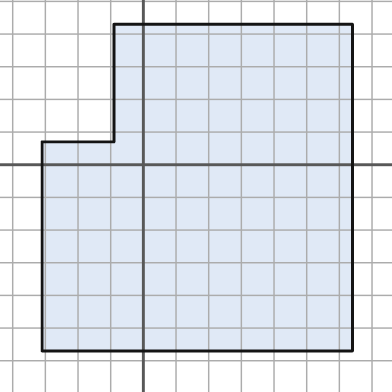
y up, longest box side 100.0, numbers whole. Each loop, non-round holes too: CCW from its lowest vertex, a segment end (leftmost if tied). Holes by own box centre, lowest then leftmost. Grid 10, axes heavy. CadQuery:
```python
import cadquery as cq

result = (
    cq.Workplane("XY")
    .moveTo(-31.0, -57.0)
    .lineTo(64.0, -57.0)
    .lineTo(64.0, 43.0)
    .lineTo(-9.0, 43.0)
    .lineTo(-9.0, 7.0)
    .lineTo(-31.0, 7.0)
    .close()
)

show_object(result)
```